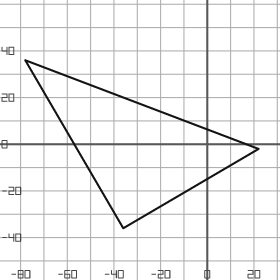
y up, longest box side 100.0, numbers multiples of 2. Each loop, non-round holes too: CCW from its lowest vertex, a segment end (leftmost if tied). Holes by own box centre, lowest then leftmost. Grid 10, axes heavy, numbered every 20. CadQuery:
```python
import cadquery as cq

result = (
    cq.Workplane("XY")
    .moveTo(-36.0, -36.0)
    .lineTo(22.0, -2.0)
    .lineTo(-78.0, 36.0)
    .close()
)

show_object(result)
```